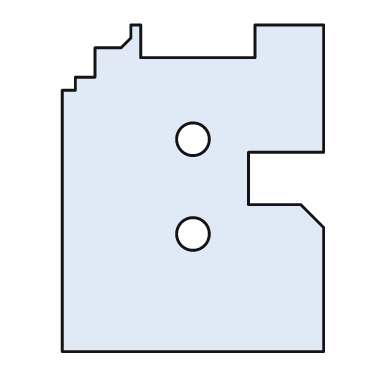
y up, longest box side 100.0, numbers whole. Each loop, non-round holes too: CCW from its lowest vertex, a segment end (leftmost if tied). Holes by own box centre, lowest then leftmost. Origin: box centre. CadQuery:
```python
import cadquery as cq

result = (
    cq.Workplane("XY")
    .moveTo(-40.0, -50.0)
    .lineTo(40.0, -50.0)
    .lineTo(40.0, -12.0)
    .lineTo(33.0, -5.0)
    .lineTo(17.0, -5.0)
    .lineTo(17.0, 11.0)
    .lineTo(40.0, 11.0)
    .lineTo(40.0, 50.0)
    .lineTo(19.0, 50.0)
    .lineTo(19.0, 40.0)
    .lineTo(-16.0, 40.0)
    .lineTo(-16.0, 50.0)
    .lineTo(-19.0, 50.0)
    .lineTo(-19.0, 46.0)
    .lineTo(-22.0, 43.0)
    .lineTo(-30.0, 43.0)
    .lineTo(-30.0, 34.0)
    .lineTo(-36.0, 34.0)
    .lineTo(-36.0, 30.0)
    .lineTo(-40.0, 30.0)
    .close()
    .moveTo(0.0, -14.0)
    .circle(5.0)
    .moveTo(0.0, 15.0)
    .circle(5.0)
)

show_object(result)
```